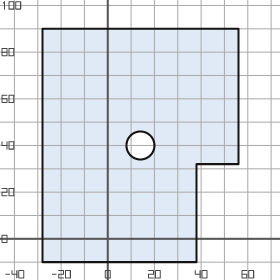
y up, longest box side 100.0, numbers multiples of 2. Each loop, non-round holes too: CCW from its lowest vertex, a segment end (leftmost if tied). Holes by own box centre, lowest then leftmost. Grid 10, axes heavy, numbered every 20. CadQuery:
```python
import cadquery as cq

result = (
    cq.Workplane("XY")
    .moveTo(-28.0, -10.0)
    .lineTo(38.0, -10.0)
    .lineTo(38.0, 32.0)
    .lineTo(56.0, 32.0)
    .lineTo(56.0, 90.0)
    .lineTo(-28.0, 90.0)
    .close()
    .moveTo(14.0, 40.0)
    .circle(6.0)
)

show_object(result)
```